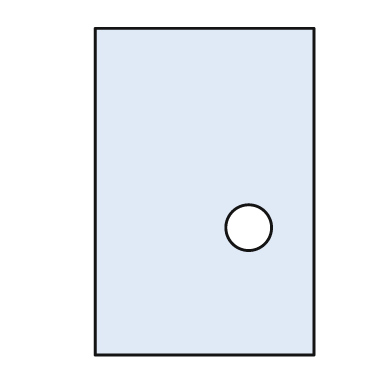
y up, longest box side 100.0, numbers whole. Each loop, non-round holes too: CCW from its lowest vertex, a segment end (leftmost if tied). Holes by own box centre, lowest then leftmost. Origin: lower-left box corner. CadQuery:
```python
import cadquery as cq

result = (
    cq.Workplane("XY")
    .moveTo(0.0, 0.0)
    .lineTo(67.0, 0.0)
    .lineTo(67.0, 100.0)
    .lineTo(0.0, 100.0)
    .close()
    .moveTo(47.0, 39.0)
    .circle(7.0)
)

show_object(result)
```